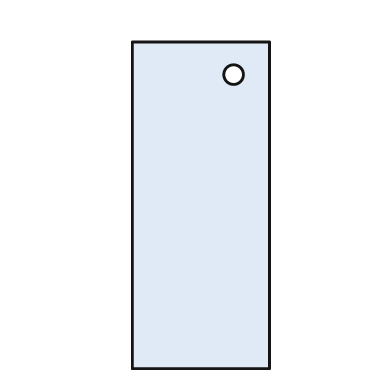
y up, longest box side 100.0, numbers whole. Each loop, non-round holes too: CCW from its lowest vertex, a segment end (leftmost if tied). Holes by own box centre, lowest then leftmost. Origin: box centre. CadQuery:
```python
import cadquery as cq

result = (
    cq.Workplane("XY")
    .moveTo(-21.0, -50.0)
    .lineTo(21.0, -50.0)
    .lineTo(21.0, 50.0)
    .lineTo(-21.0, 50.0)
    .close()
    .moveTo(10.0, 40.0)
    .circle(3.0)
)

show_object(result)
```